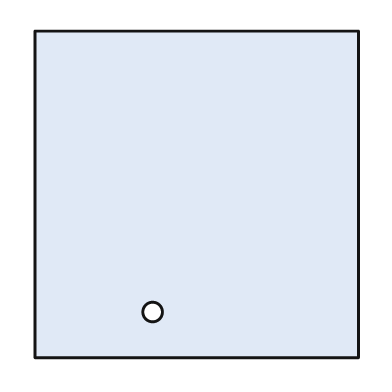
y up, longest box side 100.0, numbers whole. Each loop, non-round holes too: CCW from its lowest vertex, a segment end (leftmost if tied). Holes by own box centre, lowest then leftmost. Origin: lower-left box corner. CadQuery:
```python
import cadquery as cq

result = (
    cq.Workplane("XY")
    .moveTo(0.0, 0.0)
    .lineTo(99.0, 0.0)
    .lineTo(99.0, 100.0)
    .lineTo(0.0, 100.0)
    .close()
    .moveTo(36.0, 14.0)
    .circle(3.0)
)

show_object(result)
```